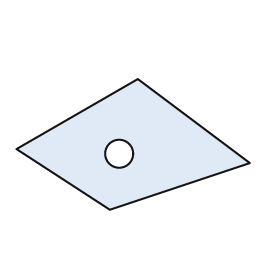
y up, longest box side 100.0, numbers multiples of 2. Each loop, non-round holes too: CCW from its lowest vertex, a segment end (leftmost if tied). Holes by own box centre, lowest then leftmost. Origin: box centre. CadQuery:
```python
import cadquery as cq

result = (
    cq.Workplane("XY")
    .moveTo(-10.0, -28.0)
    .lineTo(50.0, -8.0)
    .lineTo(2.0, 28.0)
    .lineTo(-50.0, -2.0)
    .close()
    .moveTo(-6.0, -4.0)
    .circle(6.0)
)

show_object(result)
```